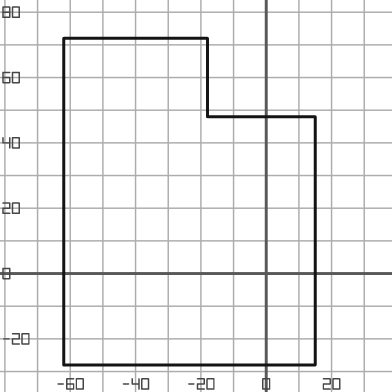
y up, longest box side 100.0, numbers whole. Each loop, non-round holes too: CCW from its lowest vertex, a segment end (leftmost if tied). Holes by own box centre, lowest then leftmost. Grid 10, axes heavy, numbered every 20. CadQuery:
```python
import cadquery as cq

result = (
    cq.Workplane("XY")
    .moveTo(-62.0, -28.0)
    .lineTo(15.0, -28.0)
    .lineTo(15.0, 48.0)
    .lineTo(-18.0, 48.0)
    .lineTo(-18.0, 72.0)
    .lineTo(-62.0, 72.0)
    .close()
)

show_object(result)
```